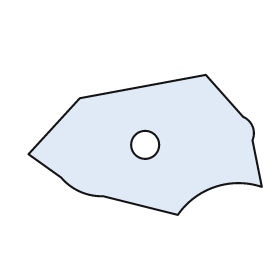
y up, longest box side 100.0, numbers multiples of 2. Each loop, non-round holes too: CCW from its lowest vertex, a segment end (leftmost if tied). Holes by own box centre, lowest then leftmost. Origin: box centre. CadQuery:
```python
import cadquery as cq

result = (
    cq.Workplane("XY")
    .moveTo(14.0, -30.0)
    .threePointArc((30.0, -18.0), (50.0, -18.0))
    .lineTo(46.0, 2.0)
    .threePointArc((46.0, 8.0), (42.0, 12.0))
    .lineTo(26.0, 30.0)
    .lineTo(-28.0, 20.0)
    .lineTo(-50.0, -4.0)
    .lineTo(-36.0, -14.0)
    .threePointArc((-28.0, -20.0), (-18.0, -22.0))
    .close()
    .moveTo(0.0, 0.0)
    .circle(6.0)
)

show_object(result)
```